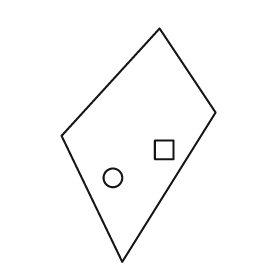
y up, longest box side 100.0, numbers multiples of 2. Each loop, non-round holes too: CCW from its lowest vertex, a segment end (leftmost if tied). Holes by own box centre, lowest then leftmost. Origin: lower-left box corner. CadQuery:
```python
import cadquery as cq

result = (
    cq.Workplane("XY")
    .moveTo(26.0, 0.0)
    .lineTo(66.0, 64.0)
    .lineTo(42.0, 100.0)
    .lineTo(0.0, 54.0)
    .close()
    .moveTo(22.0, 36.0)
    .circle(4.0)
    .moveTo(40.0, 44.0)
    .lineTo(48.0, 44.0)
    .lineTo(48.0, 52.0)
    .lineTo(40.0, 52.0)
    .close()
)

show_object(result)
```